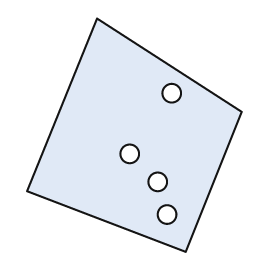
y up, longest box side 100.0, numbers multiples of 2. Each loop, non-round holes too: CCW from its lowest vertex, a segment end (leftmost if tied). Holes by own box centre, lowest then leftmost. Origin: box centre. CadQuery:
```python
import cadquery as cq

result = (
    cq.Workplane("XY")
    .moveTo(22.0, -50.0)
    .lineTo(46.0, 10.0)
    .lineTo(-16.0, 50.0)
    .lineTo(-46.0, -24.0)
    .close()
    .moveTo(14.0, -34.0)
    .circle(4.0)
    .moveTo(10.0, -20.0)
    .circle(4.0)
    .moveTo(-2.0, -8.0)
    .circle(4.0)
    .moveTo(16.0, 18.0)
    .circle(4.0)
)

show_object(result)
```